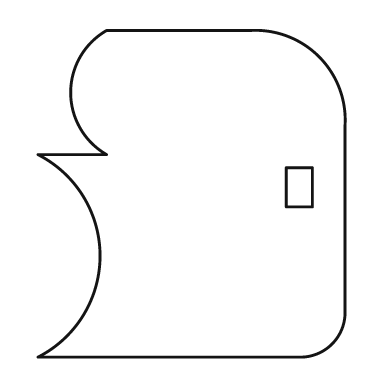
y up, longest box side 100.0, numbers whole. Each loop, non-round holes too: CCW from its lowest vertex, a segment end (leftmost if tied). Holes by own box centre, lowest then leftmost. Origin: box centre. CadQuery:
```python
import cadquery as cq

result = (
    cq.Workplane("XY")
    .moveTo(-47.0, -50.0)
    .lineTo(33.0, -50.0)
    .threePointArc((43.0, -46.0), (47.0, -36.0))
    .lineTo(47.0, 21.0)
    .threePointArc((39.0, 42.0), (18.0, 50.0))
    .lineTo(-26.0, 50.0)
    .threePointArc((-37.0, 31.0), (-26.0, 12.0))
    .lineTo(-47.0, 12.0)
    .threePointArc((-28.0, -19.0), (-47.0, -50.0))
    .close()
    .moveTo(29.0, -4.0)
    .lineTo(37.0, -4.0)
    .lineTo(37.0, 8.0)
    .lineTo(29.0, 8.0)
    .close()
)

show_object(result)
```